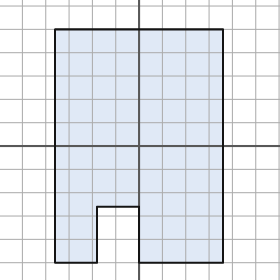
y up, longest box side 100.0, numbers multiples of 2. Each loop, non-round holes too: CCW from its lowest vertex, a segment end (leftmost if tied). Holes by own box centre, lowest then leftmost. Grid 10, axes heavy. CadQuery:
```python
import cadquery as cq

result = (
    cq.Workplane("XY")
    .moveTo(-36.0, -50.0)
    .lineTo(-18.0, -50.0)
    .lineTo(-18.0, -26.0)
    .lineTo(0.0, -26.0)
    .lineTo(0.0, -50.0)
    .lineTo(36.0, -50.0)
    .lineTo(36.0, 50.0)
    .lineTo(-36.0, 50.0)
    .close()
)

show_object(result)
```